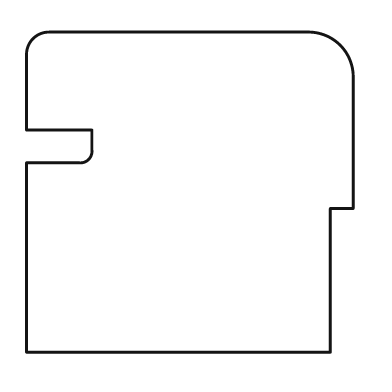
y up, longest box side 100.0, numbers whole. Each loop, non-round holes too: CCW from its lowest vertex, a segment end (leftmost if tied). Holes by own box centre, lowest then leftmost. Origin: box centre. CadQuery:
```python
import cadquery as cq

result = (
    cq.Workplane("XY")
    .moveTo(-50.0, -49.0)
    .lineTo(43.0, -49.0)
    .lineTo(43.0, -5.0)
    .lineTo(50.0, -5.0)
    .lineTo(50.0, 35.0)
    .threePointArc((46.0, 45.0), (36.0, 49.0))
    .lineTo(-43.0, 49.0)
    .threePointArc((-48.0, 47.0), (-50.0, 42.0))
    .lineTo(-50.0, 19.0)
    .lineTo(-30.0, 19.0)
    .lineTo(-30.0, 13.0)
    .threePointArc((-31.0, 10.0), (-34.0, 9.0))
    .lineTo(-50.0, 9.0)
    .close()
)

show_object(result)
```